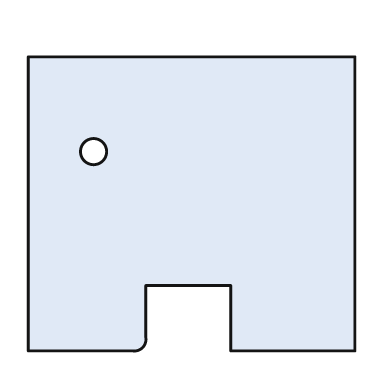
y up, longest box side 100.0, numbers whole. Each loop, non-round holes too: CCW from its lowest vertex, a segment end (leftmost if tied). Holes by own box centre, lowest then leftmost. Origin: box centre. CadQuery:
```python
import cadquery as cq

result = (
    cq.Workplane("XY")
    .moveTo(-50.0, -45.0)
    .lineTo(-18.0, -45.0)
    .threePointArc((-15.0, -44.0), (-14.0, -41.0))
    .lineTo(-14.0, -25.0)
    .lineTo(12.0, -25.0)
    .lineTo(12.0, -45.0)
    .lineTo(50.0, -45.0)
    .lineTo(50.0, 45.0)
    .lineTo(-50.0, 45.0)
    .close()
    .moveTo(-30.0, 16.0)
    .circle(4.0)
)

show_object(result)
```